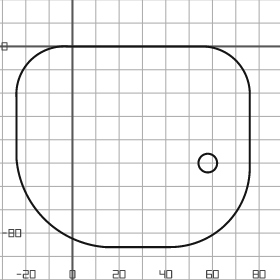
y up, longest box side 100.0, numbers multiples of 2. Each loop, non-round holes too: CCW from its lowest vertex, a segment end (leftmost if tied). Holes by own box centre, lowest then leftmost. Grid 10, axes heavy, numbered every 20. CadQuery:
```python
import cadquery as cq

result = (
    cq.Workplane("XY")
    .moveTo(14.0, -86.0)
    .lineTo(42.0, -86.0)
    .threePointArc((66.0, -76.0), (76.0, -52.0))
    .lineTo(76.0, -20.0)
    .threePointArc((70.0, -6.0), (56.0, 0.0))
    .lineTo(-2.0, 0.0)
    .threePointArc((-18.0, -6.0), (-24.0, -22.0))
    .lineTo(-24.0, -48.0)
    .threePointArc((-12.0, -74.0), (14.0, -86.0))
    .close()
    .moveTo(58.0, -50.0)
    .circle(4.0)
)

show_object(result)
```